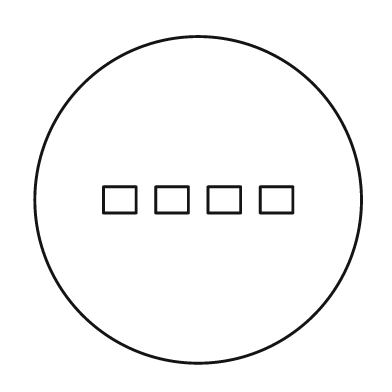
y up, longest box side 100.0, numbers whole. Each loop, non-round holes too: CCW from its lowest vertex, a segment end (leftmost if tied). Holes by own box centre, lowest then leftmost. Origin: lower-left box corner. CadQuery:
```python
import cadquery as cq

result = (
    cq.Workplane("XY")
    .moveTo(50.0, 50.0)
    .circle(50.0)
    .moveTo(21.0, 46.0)
    .lineTo(31.0, 46.0)
    .lineTo(31.0, 54.0)
    .lineTo(21.0, 54.0)
    .close()
    .moveTo(37.0, 46.0)
    .lineTo(47.0, 46.0)
    .lineTo(47.0, 54.0)
    .lineTo(37.0, 54.0)
    .close()
    .moveTo(53.0, 46.0)
    .lineTo(63.0, 46.0)
    .lineTo(63.0, 54.0)
    .lineTo(53.0, 54.0)
    .close()
    .moveTo(69.0, 46.0)
    .lineTo(79.0, 46.0)
    .lineTo(79.0, 54.0)
    .lineTo(69.0, 54.0)
    .close()
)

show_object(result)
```